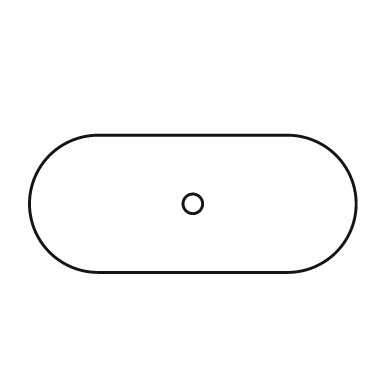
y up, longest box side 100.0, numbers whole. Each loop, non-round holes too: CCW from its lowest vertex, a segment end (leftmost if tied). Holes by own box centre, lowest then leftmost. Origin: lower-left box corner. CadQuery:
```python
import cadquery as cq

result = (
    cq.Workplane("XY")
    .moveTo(21.0, 0.0)
    .lineTo(79.0, 0.0)
    .threePointArc((100.0, 21.0), (79.0, 42.0))
    .lineTo(21.0, 42.0)
    .threePointArc((0.0, 21.0), (21.0, 0.0))
    .close()
    .moveTo(50.0, 21.0)
    .circle(3.0)
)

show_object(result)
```